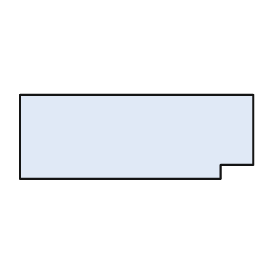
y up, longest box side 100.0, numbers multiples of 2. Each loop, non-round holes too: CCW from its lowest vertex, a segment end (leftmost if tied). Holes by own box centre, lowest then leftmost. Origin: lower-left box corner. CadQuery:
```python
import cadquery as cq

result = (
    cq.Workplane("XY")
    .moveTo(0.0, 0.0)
    .lineTo(86.0, 0.0)
    .lineTo(86.0, 6.0)
    .lineTo(100.0, 6.0)
    .lineTo(100.0, 36.0)
    .lineTo(0.0, 36.0)
    .close()
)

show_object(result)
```